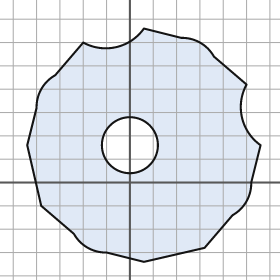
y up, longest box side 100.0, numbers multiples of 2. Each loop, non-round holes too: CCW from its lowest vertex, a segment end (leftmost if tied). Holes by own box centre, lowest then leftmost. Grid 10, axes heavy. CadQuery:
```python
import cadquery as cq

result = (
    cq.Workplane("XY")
    .moveTo(6.0, -34.0)
    .lineTo(32.0, -28.0)
    .lineTo(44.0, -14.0)
    .threePointArc((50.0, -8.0), (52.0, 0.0))
    .lineTo(56.0, 16.0)
    .threePointArc((48.0, 28.0), (50.0, 42.0))
    .lineTo(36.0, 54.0)
    .threePointArc((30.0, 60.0), (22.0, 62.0))
    .lineTo(6.0, 66.0)
    .threePointArc((-6.0, 58.0), (-20.0, 60.0))
    .lineTo(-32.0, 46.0)
    .threePointArc((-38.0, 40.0), (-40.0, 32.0))
    .lineTo(-44.0, 16.0)
    .lineTo(-38.0, -10.0)
    .lineTo(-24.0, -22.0)
    .threePointArc((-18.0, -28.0), (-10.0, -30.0))
    .close()
    .moveTo(0.0, 16.0)
    .circle(12.0)
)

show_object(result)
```